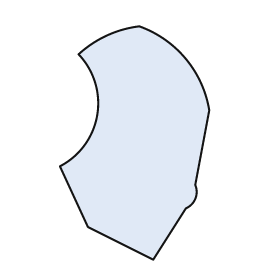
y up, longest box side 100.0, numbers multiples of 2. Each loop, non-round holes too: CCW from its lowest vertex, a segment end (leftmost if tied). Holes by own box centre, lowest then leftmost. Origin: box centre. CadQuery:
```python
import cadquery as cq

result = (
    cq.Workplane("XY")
    .moveTo(8.0, -50.0)
    .lineTo(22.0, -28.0)
    .threePointArc((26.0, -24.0), (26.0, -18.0))
    .lineTo(32.0, 14.0)
    .threePointArc((22.0, 36.0), (2.0, 50.0))
    .threePointArc((-12.0, 46.0), (-24.0, 38.0))
    .threePointArc((-16.0, 12.0), (-32.0, -10.0))
    .lineTo(-20.0, -36.0)
    .close()
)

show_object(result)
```